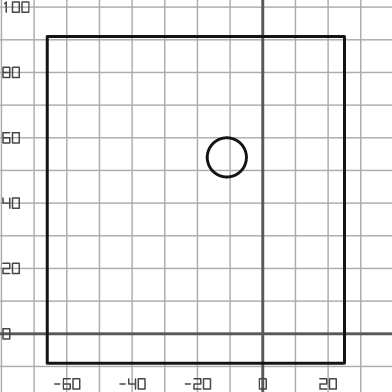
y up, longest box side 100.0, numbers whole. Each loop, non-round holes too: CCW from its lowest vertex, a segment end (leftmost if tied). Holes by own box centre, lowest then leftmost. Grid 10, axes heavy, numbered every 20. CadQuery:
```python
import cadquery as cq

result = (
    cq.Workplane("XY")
    .moveTo(-66.0, -9.0)
    .lineTo(25.0, -9.0)
    .lineTo(25.0, 91.0)
    .lineTo(-66.0, 91.0)
    .close()
    .moveTo(-11.0, 54.0)
    .circle(6.0)
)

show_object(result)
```